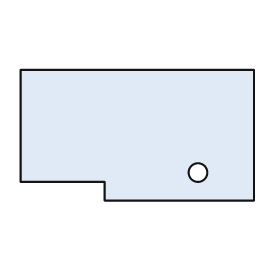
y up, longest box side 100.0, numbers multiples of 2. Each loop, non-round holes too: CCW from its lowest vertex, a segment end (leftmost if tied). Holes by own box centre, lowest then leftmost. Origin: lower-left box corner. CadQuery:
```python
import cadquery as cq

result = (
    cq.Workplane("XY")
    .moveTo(36.0, 0.0)
    .lineTo(100.0, 0.0)
    .lineTo(100.0, 56.0)
    .lineTo(0.0, 56.0)
    .lineTo(0.0, 8.0)
    .lineTo(36.0, 8.0)
    .close()
    .moveTo(76.0, 12.0)
    .circle(4.0)
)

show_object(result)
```